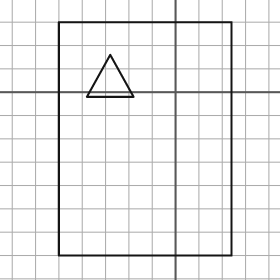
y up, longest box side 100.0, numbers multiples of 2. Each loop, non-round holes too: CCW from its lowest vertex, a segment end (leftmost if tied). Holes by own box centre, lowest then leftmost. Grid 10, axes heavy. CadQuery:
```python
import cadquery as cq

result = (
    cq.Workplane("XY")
    .moveTo(-50.0, -70.0)
    .lineTo(24.0, -70.0)
    .lineTo(24.0, 30.0)
    .lineTo(-50.0, 30.0)
    .close()
    .moveTo(-38.0, -2.0)
    .lineTo(-18.0, -2.0)
    .lineTo(-28.0, 16.0)
    .close()
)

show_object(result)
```